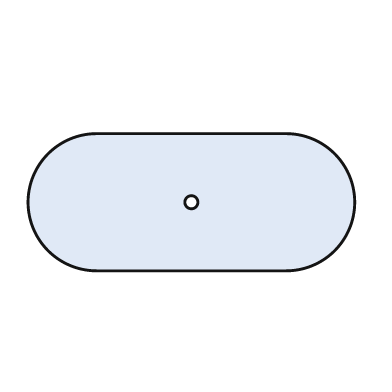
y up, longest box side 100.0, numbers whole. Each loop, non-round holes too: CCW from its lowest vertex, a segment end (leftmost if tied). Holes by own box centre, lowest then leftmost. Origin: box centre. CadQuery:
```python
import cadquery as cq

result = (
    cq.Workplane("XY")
    .moveTo(-29.0, -21.0)
    .lineTo(29.0, -21.0)
    .threePointArc((50.0, 0.0), (29.0, 21.0))
    .lineTo(-29.0, 21.0)
    .threePointArc((-50.0, 0.0), (-29.0, -21.0))
    .close()
    .moveTo(0.0, 0.0)
    .circle(2.0)
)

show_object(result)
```